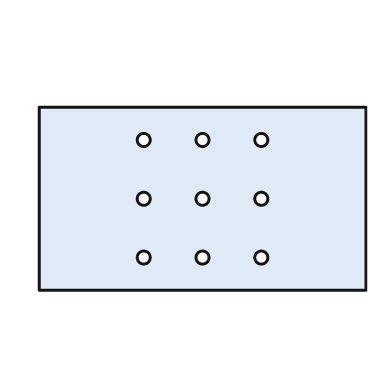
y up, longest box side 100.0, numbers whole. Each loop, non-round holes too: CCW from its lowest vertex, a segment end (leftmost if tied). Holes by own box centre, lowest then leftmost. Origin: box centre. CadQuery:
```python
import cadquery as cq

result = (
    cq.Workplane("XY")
    .moveTo(-50.0, -28.0)
    .lineTo(50.0, -28.0)
    .lineTo(50.0, 28.0)
    .lineTo(-50.0, 28.0)
    .close()
    .moveTo(-18.0, -18.0)
    .circle(2.0)
    .moveTo(0.0, -18.0)
    .circle(2.0)
    .moveTo(18.0, -18.0)
    .circle(2.0)
    .moveTo(-18.0, 0.0)
    .circle(2.0)
    .moveTo(0.0, 0.0)
    .circle(2.0)
    .moveTo(18.0, 0.0)
    .circle(2.0)
    .moveTo(-18.0, 18.0)
    .circle(2.0)
    .moveTo(0.0, 18.0)
    .circle(2.0)
    .moveTo(18.0, 18.0)
    .circle(2.0)
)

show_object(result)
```